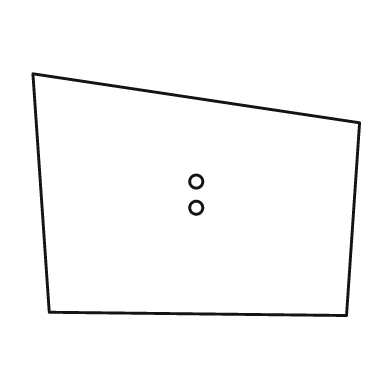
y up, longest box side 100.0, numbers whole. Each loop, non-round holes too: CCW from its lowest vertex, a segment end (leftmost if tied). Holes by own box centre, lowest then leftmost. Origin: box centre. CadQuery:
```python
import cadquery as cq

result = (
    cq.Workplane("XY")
    .moveTo(46.0, -37.0)
    .lineTo(50.0, 22.0)
    .lineTo(-50.0, 37.0)
    .lineTo(-45.0, -36.0)
    .close()
    .moveTo(0.0, -4.0)
    .circle(2.0)
    .moveTo(0.0, 4.0)
    .circle(2.0)
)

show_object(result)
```